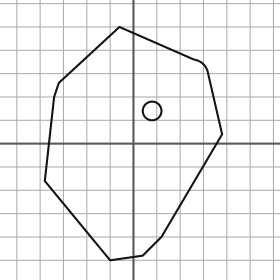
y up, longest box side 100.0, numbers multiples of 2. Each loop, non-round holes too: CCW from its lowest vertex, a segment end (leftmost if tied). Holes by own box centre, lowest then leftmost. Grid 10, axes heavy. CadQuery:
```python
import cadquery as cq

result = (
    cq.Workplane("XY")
    .moveTo(-10.0, -50.0)
    .lineTo(4.0, -48.0)
    .lineTo(12.0, -40.0)
    .lineTo(38.0, 4.0)
    .lineTo(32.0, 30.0)
    .threePointArc((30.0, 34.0), (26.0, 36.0))
    .lineTo(-6.0, 50.0)
    .lineTo(-32.0, 26.0)
    .lineTo(-34.0, 20.0)
    .lineTo(-38.0, -16.0)
    .close()
    .moveTo(8.0, 14.0)
    .circle(4.0)
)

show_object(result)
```